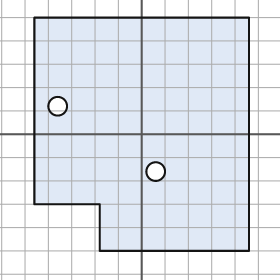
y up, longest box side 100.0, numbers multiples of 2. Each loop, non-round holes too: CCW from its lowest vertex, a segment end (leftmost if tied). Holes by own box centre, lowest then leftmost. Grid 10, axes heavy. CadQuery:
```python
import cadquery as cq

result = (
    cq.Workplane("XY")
    .moveTo(-18.0, -50.0)
    .lineTo(46.0, -50.0)
    .lineTo(46.0, 50.0)
    .lineTo(-46.0, 50.0)
    .lineTo(-46.0, -30.0)
    .lineTo(-18.0, -30.0)
    .close()
    .moveTo(6.0, -16.0)
    .circle(4.0)
    .moveTo(-36.0, 12.0)
    .circle(4.0)
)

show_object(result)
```